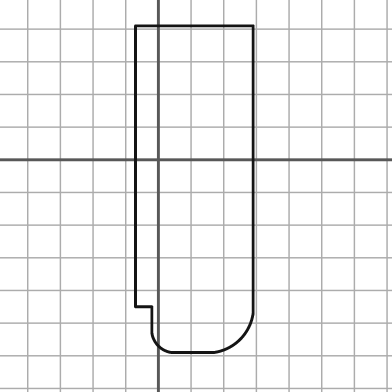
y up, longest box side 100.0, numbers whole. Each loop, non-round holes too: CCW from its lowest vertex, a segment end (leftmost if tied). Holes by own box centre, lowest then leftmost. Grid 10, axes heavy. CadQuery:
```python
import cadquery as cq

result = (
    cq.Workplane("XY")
    .moveTo(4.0, -59.0)
    .lineTo(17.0, -59.0)
    .threePointArc((25.0, -55.0), (29.0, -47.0))
    .lineTo(29.0, 41.0)
    .lineTo(-7.0, 41.0)
    .lineTo(-7.0, -45.0)
    .lineTo(-2.0, -45.0)
    .lineTo(-2.0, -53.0)
    .threePointArc((0.0, -57.0), (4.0, -59.0))
    .close()
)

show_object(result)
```